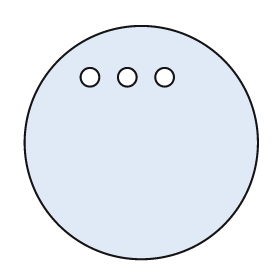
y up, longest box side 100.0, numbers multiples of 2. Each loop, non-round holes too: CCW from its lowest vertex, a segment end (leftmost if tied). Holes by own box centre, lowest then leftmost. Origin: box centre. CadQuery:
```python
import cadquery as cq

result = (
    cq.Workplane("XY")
    .moveTo(0.0, 0.0)
    .circle(50.0)
    .moveTo(-22.0, 28.0)
    .circle(4.0)
    .moveTo(-6.0, 28.0)
    .circle(4.0)
    .moveTo(10.0, 28.0)
    .circle(4.0)
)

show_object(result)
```